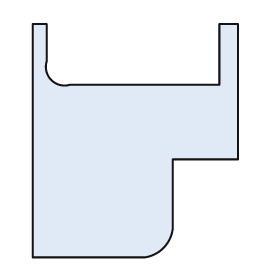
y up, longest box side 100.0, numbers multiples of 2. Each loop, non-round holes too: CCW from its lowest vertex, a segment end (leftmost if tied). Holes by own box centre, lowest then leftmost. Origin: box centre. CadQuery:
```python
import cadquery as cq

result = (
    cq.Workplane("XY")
    .moveTo(-44.0, -50.0)
    .lineTo(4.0, -50.0)
    .threePointArc((12.0, -46.0), (16.0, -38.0))
    .lineTo(16.0, -8.0)
    .lineTo(44.0, -8.0)
    .lineTo(44.0, 50.0)
    .lineTo(36.0, 50.0)
    .lineTo(36.0, 24.0)
    .lineTo(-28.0, 24.0)
    .threePointArc((-36.0, 26.0), (-38.0, 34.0))
    .lineTo(-38.0, 50.0)
    .lineTo(-44.0, 50.0)
    .close()
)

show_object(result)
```